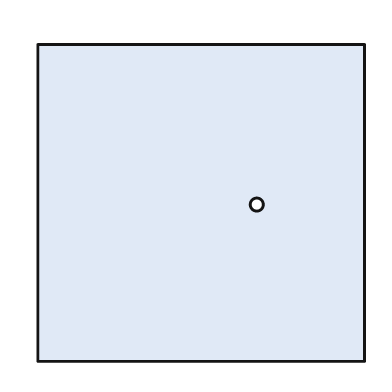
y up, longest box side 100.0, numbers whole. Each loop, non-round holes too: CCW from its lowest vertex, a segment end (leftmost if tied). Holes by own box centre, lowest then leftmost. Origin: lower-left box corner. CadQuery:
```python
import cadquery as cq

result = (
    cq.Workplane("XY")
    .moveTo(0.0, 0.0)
    .lineTo(100.0, 0.0)
    .lineTo(100.0, 97.0)
    .lineTo(0.0, 97.0)
    .close()
    .moveTo(67.0, 48.0)
    .circle(2.0)
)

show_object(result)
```